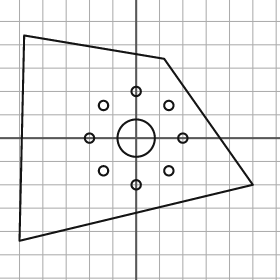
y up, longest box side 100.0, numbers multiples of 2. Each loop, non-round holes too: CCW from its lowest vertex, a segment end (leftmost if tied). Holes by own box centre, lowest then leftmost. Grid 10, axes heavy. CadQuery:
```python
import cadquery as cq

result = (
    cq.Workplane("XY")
    .moveTo(-50.0, -44.0)
    .lineTo(50.0, -20.0)
    .lineTo(12.0, 34.0)
    .lineTo(-48.0, 44.0)
    .close()
    .moveTo(0.0, -20.0)
    .circle(2.0)
    .moveTo(-14.0, -14.0)
    .circle(2.0)
    .moveTo(14.0, -14.0)
    .circle(2.0)
    .moveTo(-20.0, 0.0)
    .circle(2.0)
    .moveTo(0.0, 0.0)
    .circle(8.0)
    .moveTo(20.0, 0.0)
    .circle(2.0)
    .moveTo(-14.0, 14.0)
    .circle(2.0)
    .moveTo(14.0, 14.0)
    .circle(2.0)
    .moveTo(0.0, 20.0)
    .circle(2.0)
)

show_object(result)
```